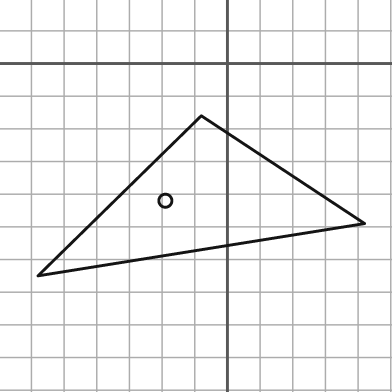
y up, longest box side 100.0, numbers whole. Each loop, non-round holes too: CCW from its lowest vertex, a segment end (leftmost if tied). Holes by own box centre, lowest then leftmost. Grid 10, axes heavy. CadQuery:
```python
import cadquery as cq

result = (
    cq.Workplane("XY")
    .moveTo(-58.0, -65.0)
    .lineTo(42.0, -49.0)
    .lineTo(-8.0, -16.0)
    .close()
    .moveTo(-19.0, -42.0)
    .circle(2.0)
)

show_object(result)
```